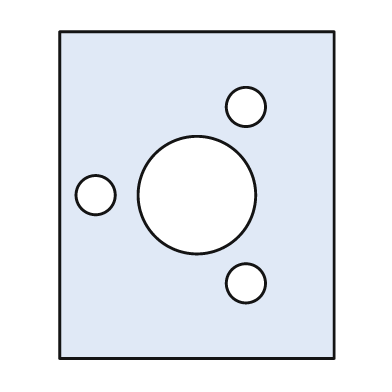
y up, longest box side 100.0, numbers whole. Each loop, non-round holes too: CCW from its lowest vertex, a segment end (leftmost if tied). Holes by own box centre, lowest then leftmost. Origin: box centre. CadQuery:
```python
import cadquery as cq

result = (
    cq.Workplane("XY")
    .moveTo(-42.0, -50.0)
    .lineTo(42.0, -50.0)
    .lineTo(42.0, 50.0)
    .lineTo(-42.0, 50.0)
    .close()
    .moveTo(15.0, -27.0)
    .circle(6.0)
    .moveTo(-31.0, 0.0)
    .circle(6.0)
    .moveTo(0.0, 0.0)
    .circle(18.0)
    .moveTo(15.0, 27.0)
    .circle(6.0)
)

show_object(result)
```